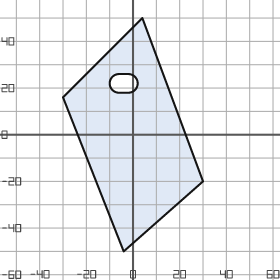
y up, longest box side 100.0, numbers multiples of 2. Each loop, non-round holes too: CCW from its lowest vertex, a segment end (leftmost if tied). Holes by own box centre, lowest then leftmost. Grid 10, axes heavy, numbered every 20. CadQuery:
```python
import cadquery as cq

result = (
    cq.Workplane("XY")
    .moveTo(-4.0, -50.0)
    .lineTo(30.0, -20.0)
    .lineTo(4.0, 50.0)
    .lineTo(-30.0, 16.0)
    .close()
    .moveTo(-6.0, 18.0)
    .lineTo(-2.0, 18.0)
    .threePointArc((2.0, 22.0), (-2.0, 26.0))
    .lineTo(-6.0, 26.0)
    .threePointArc((-10.0, 22.0), (-6.0, 18.0))
    .close()
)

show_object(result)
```